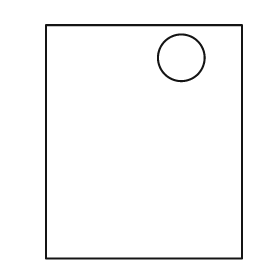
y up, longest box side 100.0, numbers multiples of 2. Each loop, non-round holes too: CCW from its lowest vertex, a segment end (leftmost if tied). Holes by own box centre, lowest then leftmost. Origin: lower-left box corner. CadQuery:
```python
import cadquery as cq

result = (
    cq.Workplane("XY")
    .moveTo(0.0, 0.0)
    .lineTo(84.0, 0.0)
    .lineTo(84.0, 100.0)
    .lineTo(0.0, 100.0)
    .close()
    .moveTo(58.0, 86.0)
    .circle(10.0)
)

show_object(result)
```